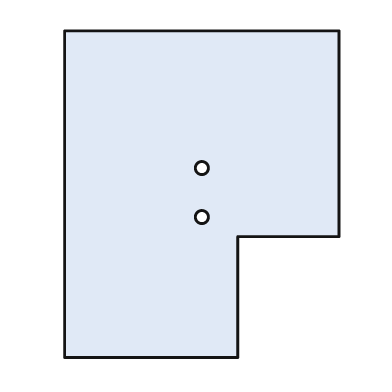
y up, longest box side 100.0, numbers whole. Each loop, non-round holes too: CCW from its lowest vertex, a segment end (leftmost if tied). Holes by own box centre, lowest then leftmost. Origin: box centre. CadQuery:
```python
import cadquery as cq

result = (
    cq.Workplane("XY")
    .moveTo(-42.0, -50.0)
    .lineTo(11.0, -50.0)
    .lineTo(11.0, -13.0)
    .lineTo(42.0, -13.0)
    .lineTo(42.0, 50.0)
    .lineTo(-42.0, 50.0)
    .close()
    .moveTo(0.0, -7.0)
    .circle(2.0)
    .moveTo(0.0, 8.0)
    .circle(2.0)
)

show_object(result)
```